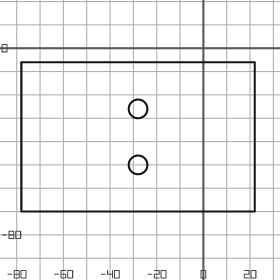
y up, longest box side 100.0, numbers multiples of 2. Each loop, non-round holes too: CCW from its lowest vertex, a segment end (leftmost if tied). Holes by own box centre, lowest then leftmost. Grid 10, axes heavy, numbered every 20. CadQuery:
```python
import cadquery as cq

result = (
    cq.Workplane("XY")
    .moveTo(-78.0, -70.0)
    .lineTo(22.0, -70.0)
    .lineTo(22.0, -6.0)
    .lineTo(-78.0, -6.0)
    .close()
    .moveTo(-28.0, -50.0)
    .circle(4.0)
    .moveTo(-28.0, -26.0)
    .circle(4.0)
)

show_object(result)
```